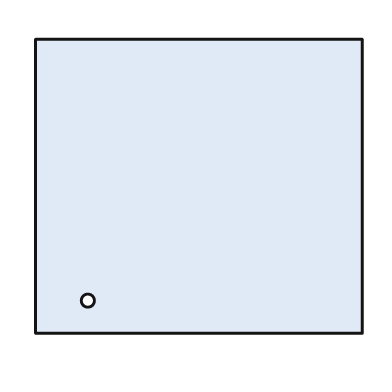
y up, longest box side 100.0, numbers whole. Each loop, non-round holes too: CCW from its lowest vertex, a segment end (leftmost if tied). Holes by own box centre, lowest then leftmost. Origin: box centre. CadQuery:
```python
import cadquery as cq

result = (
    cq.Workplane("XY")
    .moveTo(-50.0, -45.0)
    .lineTo(50.0, -45.0)
    .lineTo(50.0, 45.0)
    .lineTo(-50.0, 45.0)
    .close()
    .moveTo(-34.0, -35.0)
    .circle(2.0)
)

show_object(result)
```